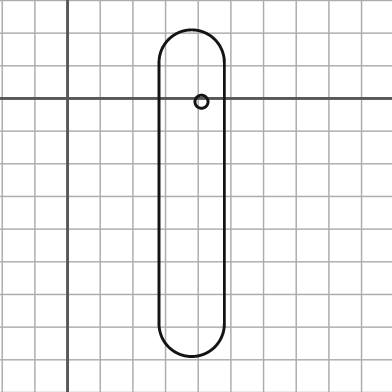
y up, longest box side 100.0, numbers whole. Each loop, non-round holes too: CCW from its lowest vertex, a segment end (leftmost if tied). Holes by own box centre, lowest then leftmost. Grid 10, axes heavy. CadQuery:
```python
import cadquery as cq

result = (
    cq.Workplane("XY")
    .moveTo(28.0, -69.0)
    .threePointArc((38.0, -79.0), (48.0, -69.0))
    .lineTo(48.0, 11.0)
    .threePointArc((38.0, 21.0), (28.0, 11.0))
    .close()
    .moveTo(41.0, -1.0)
    .circle(2.0)
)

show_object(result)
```